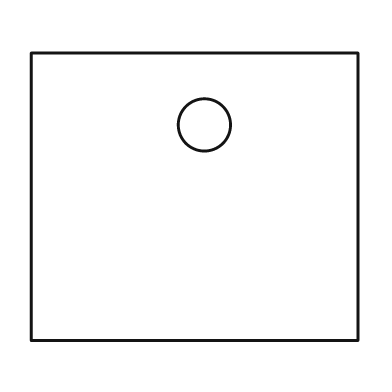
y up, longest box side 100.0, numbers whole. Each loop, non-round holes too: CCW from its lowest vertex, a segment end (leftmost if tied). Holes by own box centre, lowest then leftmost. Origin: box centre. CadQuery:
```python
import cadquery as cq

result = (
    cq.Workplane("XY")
    .moveTo(-50.0, -44.0)
    .lineTo(50.0, -44.0)
    .lineTo(50.0, 44.0)
    .lineTo(-50.0, 44.0)
    .close()
    .moveTo(3.0, 22.0)
    .circle(8.0)
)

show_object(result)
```